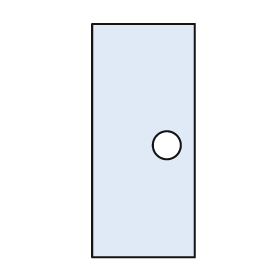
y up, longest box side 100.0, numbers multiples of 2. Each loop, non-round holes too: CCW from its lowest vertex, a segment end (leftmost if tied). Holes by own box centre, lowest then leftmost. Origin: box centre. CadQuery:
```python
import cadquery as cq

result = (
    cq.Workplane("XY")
    .moveTo(-22.0, -50.0)
    .lineTo(22.0, -50.0)
    .lineTo(22.0, 50.0)
    .lineTo(-22.0, 50.0)
    .close()
    .moveTo(10.0, -2.0)
    .circle(6.0)
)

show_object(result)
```